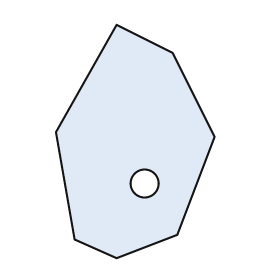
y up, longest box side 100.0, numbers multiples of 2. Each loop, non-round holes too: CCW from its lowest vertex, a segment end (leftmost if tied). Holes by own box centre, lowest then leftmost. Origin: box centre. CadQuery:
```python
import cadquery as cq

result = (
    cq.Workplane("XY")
    .moveTo(-8.0, -50.0)
    .lineTo(18.0, -40.0)
    .lineTo(34.0, 2.0)
    .lineTo(16.0, 38.0)
    .lineTo(-8.0, 50.0)
    .lineTo(-34.0, 4.0)
    .lineTo(-26.0, -42.0)
    .close()
    .moveTo(4.0, -18.0)
    .circle(6.0)
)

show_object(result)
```